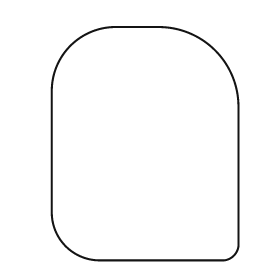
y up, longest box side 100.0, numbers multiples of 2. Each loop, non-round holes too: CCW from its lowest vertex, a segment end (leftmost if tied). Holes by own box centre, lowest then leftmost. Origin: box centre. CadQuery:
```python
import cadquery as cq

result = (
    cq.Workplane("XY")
    .moveTo(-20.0, -50.0)
    .lineTo(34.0, -50.0)
    .threePointArc((38.0, -48.0), (40.0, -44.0))
    .lineTo(40.0, 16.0)
    .threePointArc((30.0, 40.0), (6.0, 50.0))
    .lineTo(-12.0, 50.0)
    .threePointArc((-32.0, 42.0), (-40.0, 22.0))
    .lineTo(-40.0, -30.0)
    .threePointArc((-34.0, -44.0), (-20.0, -50.0))
    .close()
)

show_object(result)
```